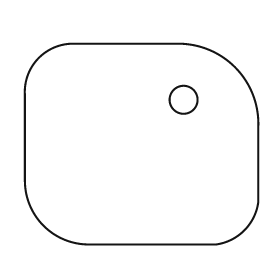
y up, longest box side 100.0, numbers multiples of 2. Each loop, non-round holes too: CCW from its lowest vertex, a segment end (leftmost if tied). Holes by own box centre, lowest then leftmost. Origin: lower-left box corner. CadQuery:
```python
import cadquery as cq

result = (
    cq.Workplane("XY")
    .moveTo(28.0, 0.0)
    .lineTo(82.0, 0.0)
    .threePointArc((94.0, 6.0), (100.0, 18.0))
    .lineTo(100.0, 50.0)
    .threePointArc((90.0, 76.0), (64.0, 86.0))
    .lineTo(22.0, 86.0)
    .threePointArc((6.0, 80.0), (0.0, 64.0))
    .lineTo(0.0, 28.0)
    .threePointArc((8.0, 8.0), (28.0, 0.0))
    .close()
    .moveTo(68.0, 62.0)
    .circle(6.0)
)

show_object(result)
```